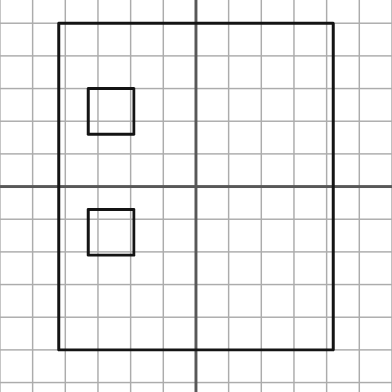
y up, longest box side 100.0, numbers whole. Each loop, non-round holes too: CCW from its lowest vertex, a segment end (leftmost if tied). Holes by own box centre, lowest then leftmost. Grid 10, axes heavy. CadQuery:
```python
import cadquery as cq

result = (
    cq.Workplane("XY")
    .moveTo(-42.0, -50.0)
    .lineTo(42.0, -50.0)
    .lineTo(42.0, 50.0)
    .lineTo(-42.0, 50.0)
    .close()
    .moveTo(-33.0, -21.0)
    .lineTo(-19.0, -21.0)
    .lineTo(-19.0, -7.0)
    .lineTo(-33.0, -7.0)
    .close()
    .moveTo(-33.0, 16.0)
    .lineTo(-19.0, 16.0)
    .lineTo(-19.0, 30.0)
    .lineTo(-33.0, 30.0)
    .close()
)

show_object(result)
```